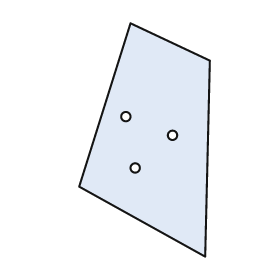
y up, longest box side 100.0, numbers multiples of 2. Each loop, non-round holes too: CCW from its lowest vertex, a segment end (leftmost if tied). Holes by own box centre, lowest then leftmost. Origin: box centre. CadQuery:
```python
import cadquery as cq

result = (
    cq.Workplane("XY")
    .moveTo(26.0, -50.0)
    .lineTo(28.0, 34.0)
    .lineTo(-6.0, 50.0)
    .lineTo(-28.0, -20.0)
    .close()
    .moveTo(-4.0, -12.0)
    .circle(2.0)
    .moveTo(12.0, 2.0)
    .circle(2.0)
    .moveTo(-8.0, 10.0)
    .circle(2.0)
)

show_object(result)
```